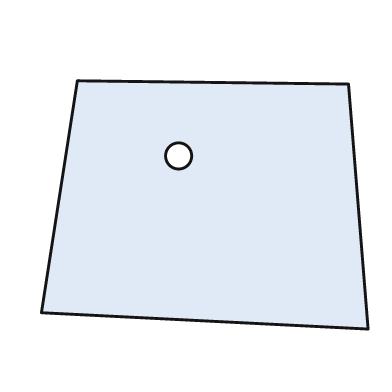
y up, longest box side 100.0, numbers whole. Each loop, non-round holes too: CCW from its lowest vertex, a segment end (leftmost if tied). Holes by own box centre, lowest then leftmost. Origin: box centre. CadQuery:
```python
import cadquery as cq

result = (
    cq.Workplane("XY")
    .moveTo(50.0, -38.0)
    .lineTo(44.0, 37.0)
    .lineTo(-39.0, 38.0)
    .lineTo(-50.0, -33.0)
    .close()
    .moveTo(-8.0, 15.0)
    .circle(4.0)
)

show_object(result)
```